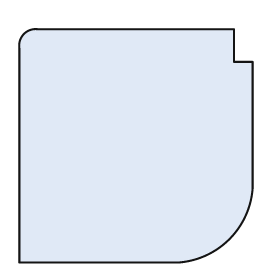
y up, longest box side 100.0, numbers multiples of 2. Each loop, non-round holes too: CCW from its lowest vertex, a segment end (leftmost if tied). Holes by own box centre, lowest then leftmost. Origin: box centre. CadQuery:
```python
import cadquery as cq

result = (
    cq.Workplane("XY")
    .moveTo(-50.0, -50.0)
    .lineTo(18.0, -50.0)
    .threePointArc((40.0, -40.0), (50.0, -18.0))
    .lineTo(50.0, 36.0)
    .lineTo(42.0, 36.0)
    .lineTo(42.0, 50.0)
    .lineTo(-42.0, 50.0)
    .threePointArc((-48.0, 48.0), (-50.0, 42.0))
    .close()
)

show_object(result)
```